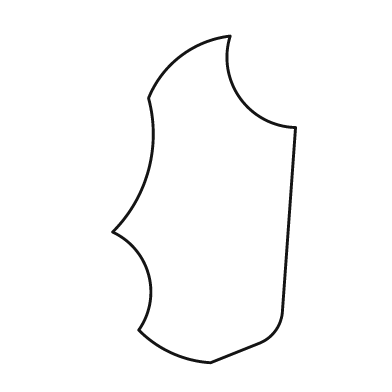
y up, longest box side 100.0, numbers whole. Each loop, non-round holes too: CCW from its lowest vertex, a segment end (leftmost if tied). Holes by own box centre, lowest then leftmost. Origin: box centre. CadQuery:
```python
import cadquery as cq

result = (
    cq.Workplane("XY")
    .moveTo(2.0, -50.0)
    .lineTo(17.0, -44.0)
    .threePointArc((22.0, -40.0), (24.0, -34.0))
    .lineTo(28.0, 22.0)
    .threePointArc((11.0, 31.0), (8.0, 50.0))
    .threePointArc((-7.0, 44.0), (-17.0, 31.0))
    .threePointArc((-17.0, 9.0), (-28.0, -10.0))
    .threePointArc((-17.0, -23.0), (-20.0, -40.0))
    .threePointArc((-10.0, -47.0), (2.0, -50.0))
    .close()
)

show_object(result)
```